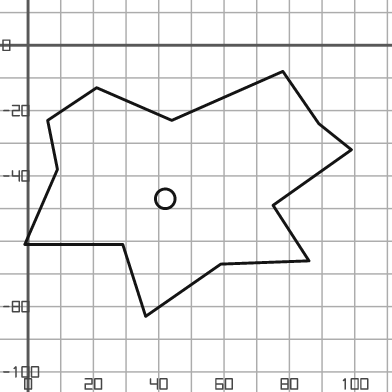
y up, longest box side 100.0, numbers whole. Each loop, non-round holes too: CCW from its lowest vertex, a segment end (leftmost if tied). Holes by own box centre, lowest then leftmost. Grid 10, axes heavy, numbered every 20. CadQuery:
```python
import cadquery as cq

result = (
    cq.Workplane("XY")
    .moveTo(36.0, -83.0)
    .lineTo(59.0, -67.0)
    .lineTo(86.0, -66.0)
    .lineTo(75.0, -49.0)
    .lineTo(99.0, -32.0)
    .lineTo(89.0, -24.0)
    .lineTo(78.0, -8.0)
    .lineTo(44.0, -23.0)
    .lineTo(21.0, -13.0)
    .lineTo(6.0, -23.0)
    .lineTo(9.0, -38.0)
    .lineTo(-1.0, -61.0)
    .lineTo(29.0, -61.0)
    .close()
    .moveTo(42.0, -47.0)
    .circle(3.0)
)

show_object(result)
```